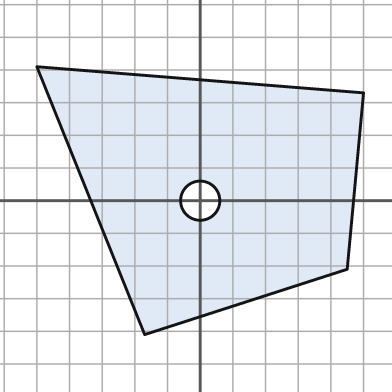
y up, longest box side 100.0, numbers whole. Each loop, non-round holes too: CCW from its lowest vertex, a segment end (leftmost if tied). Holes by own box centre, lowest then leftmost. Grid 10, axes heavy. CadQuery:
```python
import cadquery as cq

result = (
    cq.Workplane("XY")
    .moveTo(-17.0, -41.0)
    .lineTo(45.0, -21.0)
    .lineTo(50.0, 33.0)
    .lineTo(-50.0, 41.0)
    .close()
    .moveTo(0.0, 0.0)
    .circle(6.0)
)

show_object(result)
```